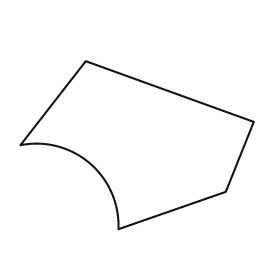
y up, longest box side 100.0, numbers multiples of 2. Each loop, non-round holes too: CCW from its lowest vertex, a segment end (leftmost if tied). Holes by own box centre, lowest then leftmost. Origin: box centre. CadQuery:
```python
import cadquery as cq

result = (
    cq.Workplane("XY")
    .moveTo(-8.0, -36.0)
    .lineTo(38.0, -20.0)
    .lineTo(50.0, 10.0)
    .lineTo(-22.0, 36.0)
    .lineTo(-50.0, 0.0)
    .threePointArc((-20.0, -8.0), (-8.0, -36.0))
    .close()
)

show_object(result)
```